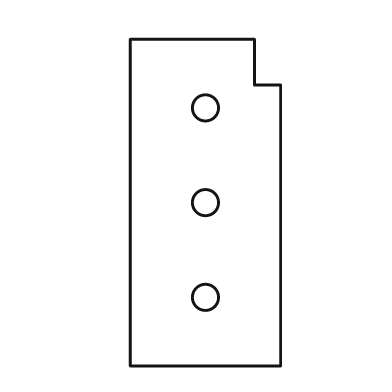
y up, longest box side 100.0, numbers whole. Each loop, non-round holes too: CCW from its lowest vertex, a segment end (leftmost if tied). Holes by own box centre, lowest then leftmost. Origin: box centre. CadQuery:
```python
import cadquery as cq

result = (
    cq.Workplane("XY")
    .moveTo(-23.0, -50.0)
    .lineTo(23.0, -50.0)
    .lineTo(23.0, 36.0)
    .lineTo(15.0, 36.0)
    .lineTo(15.0, 50.0)
    .lineTo(-23.0, 50.0)
    .close()
    .moveTo(0.0, -29.0)
    .circle(4.0)
    .moveTo(0.0, 0.0)
    .circle(4.0)
    .moveTo(0.0, 29.0)
    .circle(4.0)
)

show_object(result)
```